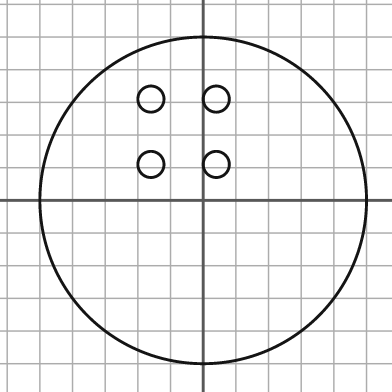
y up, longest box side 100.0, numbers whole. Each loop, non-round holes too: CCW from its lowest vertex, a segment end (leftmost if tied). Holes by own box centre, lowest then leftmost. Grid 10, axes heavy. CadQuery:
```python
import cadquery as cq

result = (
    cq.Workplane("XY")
    .moveTo(0.0, 0.0)
    .circle(50.0)
    .moveTo(-16.0, 11.0)
    .circle(4.0)
    .moveTo(4.0, 11.0)
    .circle(4.0)
    .moveTo(-16.0, 31.0)
    .circle(4.0)
    .moveTo(4.0, 31.0)
    .circle(4.0)
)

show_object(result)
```